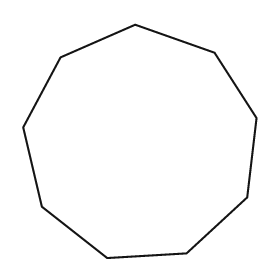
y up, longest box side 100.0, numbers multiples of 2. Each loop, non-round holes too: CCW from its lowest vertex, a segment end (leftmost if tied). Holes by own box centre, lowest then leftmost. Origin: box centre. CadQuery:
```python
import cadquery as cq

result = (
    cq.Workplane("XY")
    .moveTo(-14.0, -50.0)
    .lineTo(20.0, -48.0)
    .lineTo(46.0, -24.0)
    .lineTo(50.0, 10.0)
    .lineTo(32.0, 38.0)
    .lineTo(-2.0, 50.0)
    .lineTo(-34.0, 36.0)
    .lineTo(-50.0, 6.0)
    .lineTo(-42.0, -28.0)
    .close()
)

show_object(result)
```